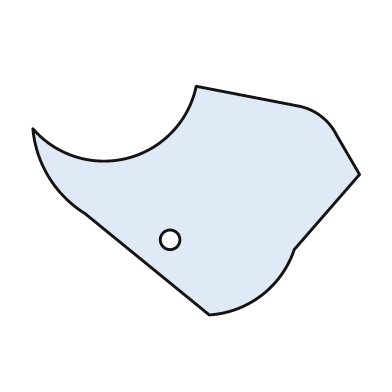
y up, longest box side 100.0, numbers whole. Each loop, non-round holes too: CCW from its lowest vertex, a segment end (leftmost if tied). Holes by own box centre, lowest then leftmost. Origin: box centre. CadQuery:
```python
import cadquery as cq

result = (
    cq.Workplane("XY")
    .moveTo(4.0, -35.0)
    .threePointArc((20.0, -29.0), (30.0, -15.0))
    .lineTo(50.0, 8.0)
    .lineTo(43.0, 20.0)
    .threePointArc((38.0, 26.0), (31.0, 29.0))
    .lineTo(0.0, 35.0)
    .threePointArc((-21.0, 13.0), (-50.0, 22.0))
    .threePointArc((-45.0, 7.0), (-34.0, -4.0))
    .close()
    .moveTo(-8.0, -12.0)
    .circle(3.0)
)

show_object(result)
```